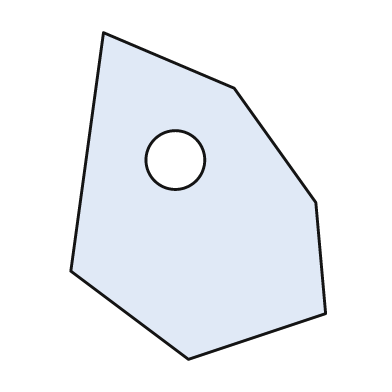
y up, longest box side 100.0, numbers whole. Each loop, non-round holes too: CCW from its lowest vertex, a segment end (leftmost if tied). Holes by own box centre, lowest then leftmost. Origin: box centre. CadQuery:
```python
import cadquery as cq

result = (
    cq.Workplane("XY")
    .moveTo(-3.0, -50.0)
    .lineTo(39.0, -36.0)
    .lineTo(36.0, -2.0)
    .lineTo(11.0, 33.0)
    .lineTo(-29.0, 50.0)
    .lineTo(-39.0, -23.0)
    .close()
    .moveTo(-7.0, 11.0)
    .circle(9.0)
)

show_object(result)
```